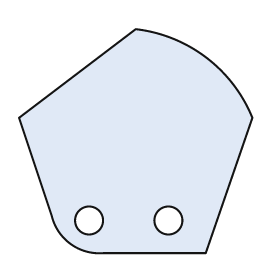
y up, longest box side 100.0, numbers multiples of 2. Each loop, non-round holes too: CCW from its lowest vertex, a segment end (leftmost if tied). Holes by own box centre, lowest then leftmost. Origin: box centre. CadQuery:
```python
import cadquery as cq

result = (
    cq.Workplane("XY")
    .moveTo(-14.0, -48.0)
    .lineTo(30.0, -48.0)
    .lineTo(50.0, 10.0)
    .threePointArc((30.0, 36.0), (0.0, 48.0))
    .lineTo(-50.0, 10.0)
    .lineTo(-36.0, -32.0)
    .threePointArc((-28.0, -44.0), (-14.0, -48.0))
    .close()
    .moveTo(-20.0, -34.0)
    .circle(6.0)
    .moveTo(14.0, -34.0)
    .circle(6.0)
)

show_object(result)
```